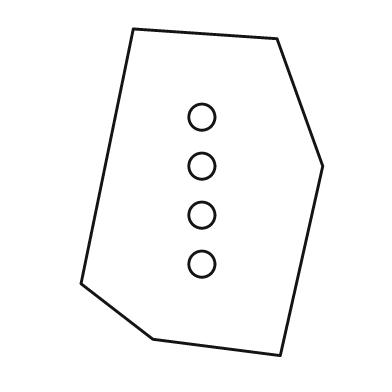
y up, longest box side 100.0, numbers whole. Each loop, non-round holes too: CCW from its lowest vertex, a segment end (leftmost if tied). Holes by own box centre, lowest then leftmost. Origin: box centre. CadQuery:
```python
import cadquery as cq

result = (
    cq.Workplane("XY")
    .moveTo(24.0, -50.0)
    .lineTo(37.0, 8.0)
    .lineTo(23.0, 47.0)
    .lineTo(-21.0, 50.0)
    .lineTo(-37.0, -28.0)
    .lineTo(-15.0, -45.0)
    .close()
    .moveTo(0.0, -22.0)
    .circle(4.0)
    .moveTo(0.0, -7.0)
    .circle(4.0)
    .moveTo(0.0, 8.0)
    .circle(4.0)
    .moveTo(0.0, 23.0)
    .circle(4.0)
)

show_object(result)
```